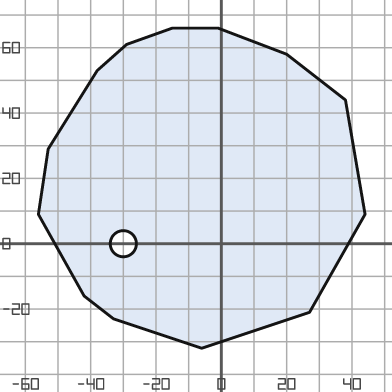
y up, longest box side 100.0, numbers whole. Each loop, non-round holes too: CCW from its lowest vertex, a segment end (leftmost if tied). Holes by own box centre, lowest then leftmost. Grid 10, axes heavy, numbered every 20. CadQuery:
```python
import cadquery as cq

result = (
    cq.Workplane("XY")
    .moveTo(-6.0, -32.0)
    .lineTo(27.0, -21.0)
    .lineTo(44.0, 9.0)
    .lineTo(38.0, 44.0)
    .lineTo(20.0, 58.0)
    .lineTo(-1.0, 66.0)
    .lineTo(-15.0, 66.0)
    .lineTo(-29.0, 61.0)
    .lineTo(-38.0, 53.0)
    .lineTo(-53.0, 29.0)
    .lineTo(-56.0, 9.0)
    .lineTo(-42.0, -16.0)
    .lineTo(-33.0, -23.0)
    .close()
    .moveTo(-30.0, 0.0)
    .circle(4.0)
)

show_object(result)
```